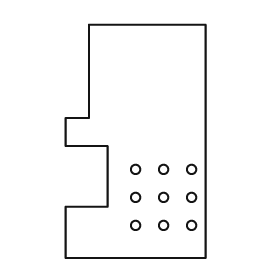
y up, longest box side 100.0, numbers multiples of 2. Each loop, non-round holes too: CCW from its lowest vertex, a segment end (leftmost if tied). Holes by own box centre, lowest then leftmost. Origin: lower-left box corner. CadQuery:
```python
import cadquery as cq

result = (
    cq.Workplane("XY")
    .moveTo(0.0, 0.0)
    .lineTo(60.0, 0.0)
    .lineTo(60.0, 100.0)
    .lineTo(10.0, 100.0)
    .lineTo(10.0, 60.0)
    .lineTo(0.0, 60.0)
    .lineTo(0.0, 48.0)
    .lineTo(18.0, 48.0)
    .lineTo(18.0, 22.0)
    .lineTo(0.0, 22.0)
    .close()
    .moveTo(30.0, 14.0)
    .circle(2.0)
    .moveTo(42.0, 14.0)
    .circle(2.0)
    .moveTo(54.0, 14.0)
    .circle(2.0)
    .moveTo(30.0, 26.0)
    .circle(2.0)
    .moveTo(42.0, 26.0)
    .circle(2.0)
    .moveTo(54.0, 26.0)
    .circle(2.0)
    .moveTo(30.0, 38.0)
    .circle(2.0)
    .moveTo(42.0, 38.0)
    .circle(2.0)
    .moveTo(54.0, 38.0)
    .circle(2.0)
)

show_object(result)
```